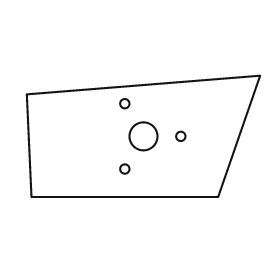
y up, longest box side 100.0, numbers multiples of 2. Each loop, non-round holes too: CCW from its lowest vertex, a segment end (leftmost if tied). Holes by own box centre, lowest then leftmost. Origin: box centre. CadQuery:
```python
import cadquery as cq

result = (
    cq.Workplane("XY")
    .moveTo(-48.0, -26.0)
    .lineTo(32.0, -26.0)
    .lineTo(50.0, 26.0)
    .lineTo(-50.0, 18.0)
    .close()
    .moveTo(-8.0, -14.0)
    .circle(2.0)
    .moveTo(0.0, 0.0)
    .circle(6.0)
    .moveTo(16.0, 0.0)
    .circle(2.0)
    .moveTo(-8.0, 14.0)
    .circle(2.0)
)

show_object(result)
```